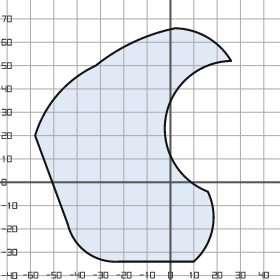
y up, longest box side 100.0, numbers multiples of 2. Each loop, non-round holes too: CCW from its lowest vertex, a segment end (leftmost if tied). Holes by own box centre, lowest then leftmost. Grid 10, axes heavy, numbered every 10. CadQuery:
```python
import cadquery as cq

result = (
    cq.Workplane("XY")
    .moveTo(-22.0, -34.0)
    .lineTo(10.0, -34.0)
    .threePointArc((18.0, -20.0), (16.0, -4.0))
    .threePointArc((-2.0, 28.0), (26.0, 52.0))
    .threePointArc((16.0, 62.0), (2.0, 66.0))
    .threePointArc((-16.0, 60.0), (-32.0, 50.0))
    .threePointArc((-48.0, 38.0), (-58.0, 20.0))
    .lineTo(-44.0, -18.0)
    .threePointArc((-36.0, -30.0), (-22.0, -34.0))
    .close()
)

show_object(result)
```